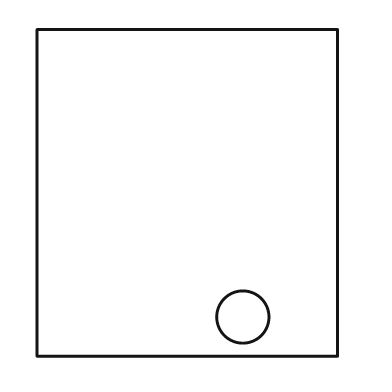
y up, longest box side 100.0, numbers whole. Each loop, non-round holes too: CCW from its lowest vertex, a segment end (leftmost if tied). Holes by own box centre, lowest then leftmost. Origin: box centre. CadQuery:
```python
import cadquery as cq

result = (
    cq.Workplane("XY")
    .moveTo(-46.0, -50.0)
    .lineTo(46.0, -50.0)
    .lineTo(46.0, 50.0)
    .lineTo(-46.0, 50.0)
    .close()
    .moveTo(17.0, -38.0)
    .circle(8.0)
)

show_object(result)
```